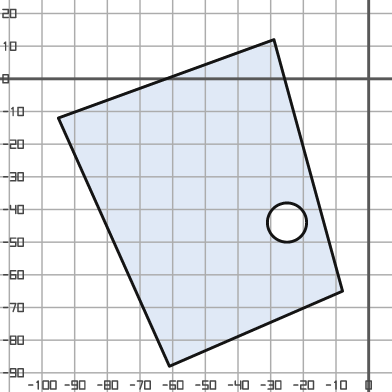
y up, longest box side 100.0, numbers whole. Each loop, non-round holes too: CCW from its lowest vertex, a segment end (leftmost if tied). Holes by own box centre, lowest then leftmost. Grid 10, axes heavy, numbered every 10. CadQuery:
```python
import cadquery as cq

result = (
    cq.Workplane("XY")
    .moveTo(-61.0, -88.0)
    .lineTo(-8.0, -65.0)
    .lineTo(-29.0, 12.0)
    .lineTo(-95.0, -12.0)
    .close()
    .moveTo(-25.0, -44.0)
    .circle(6.0)
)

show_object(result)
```